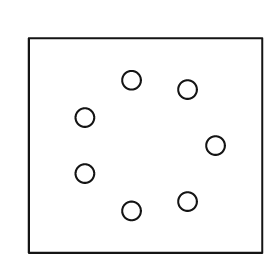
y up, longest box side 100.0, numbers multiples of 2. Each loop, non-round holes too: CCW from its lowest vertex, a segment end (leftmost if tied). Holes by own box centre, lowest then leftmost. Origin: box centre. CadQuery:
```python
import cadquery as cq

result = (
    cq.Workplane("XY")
    .moveTo(-50.0, -46.0)
    .lineTo(50.0, -46.0)
    .lineTo(50.0, 46.0)
    .lineTo(-50.0, 46.0)
    .close()
    .moveTo(-6.0, -28.0)
    .circle(4.0)
    .moveTo(18.0, -24.0)
    .circle(4.0)
    .moveTo(-26.0, -12.0)
    .circle(4.0)
    .moveTo(30.0, 0.0)
    .circle(4.0)
    .moveTo(-26.0, 12.0)
    .circle(4.0)
    .moveTo(18.0, 24.0)
    .circle(4.0)
    .moveTo(-6.0, 28.0)
    .circle(4.0)
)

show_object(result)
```